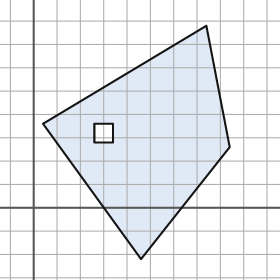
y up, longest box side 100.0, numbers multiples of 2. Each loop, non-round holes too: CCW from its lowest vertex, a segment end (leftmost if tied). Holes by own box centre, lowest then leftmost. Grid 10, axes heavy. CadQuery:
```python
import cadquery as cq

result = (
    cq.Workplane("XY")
    .moveTo(46.0, -22.0)
    .lineTo(84.0, 26.0)
    .lineTo(74.0, 78.0)
    .lineTo(4.0, 36.0)
    .close()
    .moveTo(26.0, 28.0)
    .lineTo(34.0, 28.0)
    .lineTo(34.0, 36.0)
    .lineTo(26.0, 36.0)
    .close()
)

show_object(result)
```